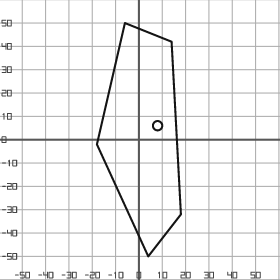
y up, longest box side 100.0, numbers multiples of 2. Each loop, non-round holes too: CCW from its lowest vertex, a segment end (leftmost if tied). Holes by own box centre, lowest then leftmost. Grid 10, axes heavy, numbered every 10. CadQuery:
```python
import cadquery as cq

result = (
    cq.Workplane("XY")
    .moveTo(4.0, -50.0)
    .lineTo(18.0, -32.0)
    .lineTo(14.0, 42.0)
    .lineTo(-6.0, 50.0)
    .lineTo(-18.0, -2.0)
    .close()
    .moveTo(8.0, 6.0)
    .circle(2.0)
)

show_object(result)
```